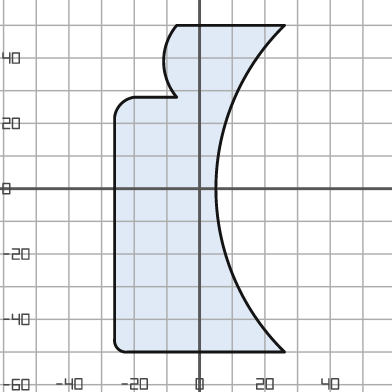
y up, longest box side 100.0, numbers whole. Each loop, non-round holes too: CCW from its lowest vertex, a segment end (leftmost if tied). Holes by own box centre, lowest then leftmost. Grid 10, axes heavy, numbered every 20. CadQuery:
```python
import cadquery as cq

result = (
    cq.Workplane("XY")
    .moveTo(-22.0, -50.0)
    .lineTo(26.0, -50.0)
    .threePointArc((5.0, 0.0), (26.0, 50.0))
    .lineTo(-7.0, 50.0)
    .threePointArc((-11.0, 39.0), (-7.0, 28.0))
    .lineTo(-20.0, 28.0)
    .threePointArc((-24.0, 26.0), (-26.0, 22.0))
    .lineTo(-26.0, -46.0)
    .threePointArc((-25.0, -49.0), (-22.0, -50.0))
    .close()
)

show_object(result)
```